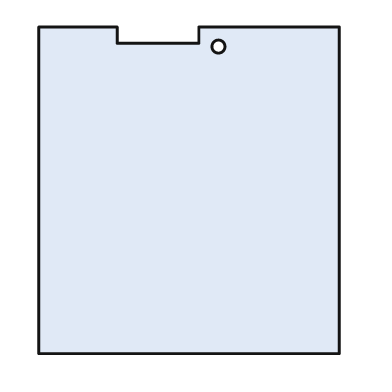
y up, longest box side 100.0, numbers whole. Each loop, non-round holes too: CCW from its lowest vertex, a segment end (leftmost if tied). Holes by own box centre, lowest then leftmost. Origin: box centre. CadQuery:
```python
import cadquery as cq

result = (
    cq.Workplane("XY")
    .moveTo(-46.0, -50.0)
    .lineTo(46.0, -50.0)
    .lineTo(46.0, 50.0)
    .lineTo(3.0, 50.0)
    .lineTo(3.0, 45.0)
    .lineTo(-22.0, 45.0)
    .lineTo(-22.0, 50.0)
    .lineTo(-46.0, 50.0)
    .close()
    .moveTo(9.0, 44.0)
    .circle(2.0)
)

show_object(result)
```